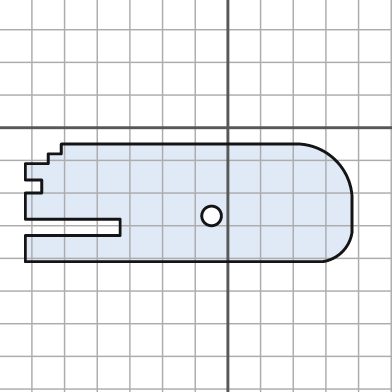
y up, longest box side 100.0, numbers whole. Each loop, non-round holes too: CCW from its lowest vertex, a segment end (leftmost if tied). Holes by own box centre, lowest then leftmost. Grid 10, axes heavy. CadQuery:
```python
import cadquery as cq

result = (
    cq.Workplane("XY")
    .moveTo(-62.0, -41.0)
    .lineTo(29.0, -41.0)
    .threePointArc((35.0, -38.0), (38.0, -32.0))
    .lineTo(38.0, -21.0)
    .threePointArc((33.0, -10.0), (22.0, -5.0))
    .lineTo(-51.0, -5.0)
    .lineTo(-51.0, -8.0)
    .lineTo(-55.0, -8.0)
    .lineTo(-55.0, -11.0)
    .lineTo(-62.0, -11.0)
    .lineTo(-62.0, -16.0)
    .lineTo(-57.0, -16.0)
    .lineTo(-57.0, -20.0)
    .lineTo(-62.0, -20.0)
    .lineTo(-62.0, -28.0)
    .lineTo(-33.0, -28.0)
    .lineTo(-33.0, -33.0)
    .lineTo(-62.0, -33.0)
    .close()
    .moveTo(-5.0, -27.0)
    .circle(3.0)
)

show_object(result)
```